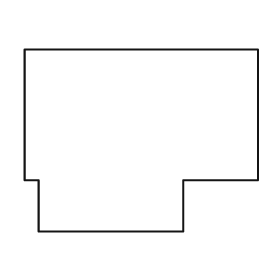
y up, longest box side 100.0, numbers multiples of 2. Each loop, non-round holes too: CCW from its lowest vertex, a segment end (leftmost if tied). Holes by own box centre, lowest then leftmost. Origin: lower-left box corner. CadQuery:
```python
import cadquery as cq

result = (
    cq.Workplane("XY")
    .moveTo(6.0, 0.0)
    .lineTo(68.0, 0.0)
    .lineTo(68.0, 22.0)
    .lineTo(100.0, 22.0)
    .lineTo(100.0, 78.0)
    .lineTo(0.0, 78.0)
    .lineTo(0.0, 22.0)
    .lineTo(6.0, 22.0)
    .close()
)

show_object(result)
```